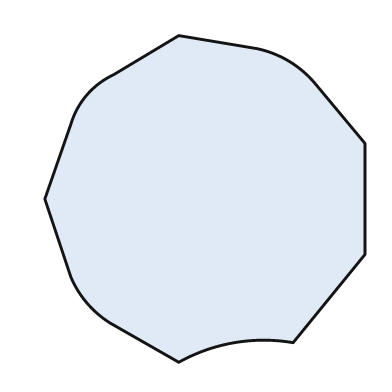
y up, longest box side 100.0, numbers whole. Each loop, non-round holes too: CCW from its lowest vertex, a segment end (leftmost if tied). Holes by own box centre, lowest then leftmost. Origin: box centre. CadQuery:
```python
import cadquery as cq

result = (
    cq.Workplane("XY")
    .moveTo(-8.0, -50.0)
    .threePointArc((9.0, -44.0), (27.0, -44.0))
    .lineTo(49.0, -17.0)
    .lineTo(49.0, 17.0)
    .lineTo(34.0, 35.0)
    .threePointArc((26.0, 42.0), (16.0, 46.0))
    .lineTo(-8.0, 50.0)
    .lineTo(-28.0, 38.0)
    .threePointArc((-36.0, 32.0), (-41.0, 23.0))
    .lineTo(-49.0, 0.0)
    .lineTo(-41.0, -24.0)
    .threePointArc((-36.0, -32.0), (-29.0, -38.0))
    .close()
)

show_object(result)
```